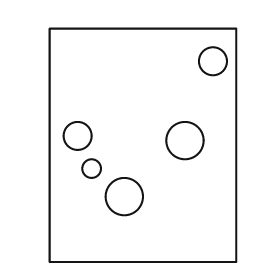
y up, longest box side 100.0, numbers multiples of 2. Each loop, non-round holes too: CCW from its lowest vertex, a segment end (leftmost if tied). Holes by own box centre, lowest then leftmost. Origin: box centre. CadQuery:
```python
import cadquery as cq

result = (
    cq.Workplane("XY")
    .moveTo(-40.0, -50.0)
    .lineTo(40.0, -50.0)
    .lineTo(40.0, 50.0)
    .lineTo(-40.0, 50.0)
    .close()
    .moveTo(-8.0, -22.0)
    .circle(8.0)
    .moveTo(-22.0, -10.0)
    .circle(4.0)
    .moveTo(18.0, 2.0)
    .circle(8.0)
    .moveTo(-28.0, 4.0)
    .circle(6.0)
    .moveTo(30.0, 36.0)
    .circle(6.0)
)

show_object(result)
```